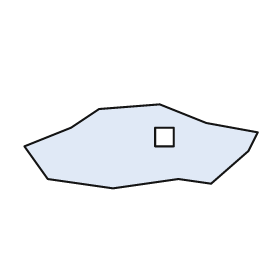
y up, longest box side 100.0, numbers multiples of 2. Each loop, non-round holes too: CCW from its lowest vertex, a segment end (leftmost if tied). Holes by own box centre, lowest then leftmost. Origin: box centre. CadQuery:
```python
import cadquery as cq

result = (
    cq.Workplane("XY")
    .moveTo(-12.0, -18.0)
    .lineTo(16.0, -14.0)
    .lineTo(30.0, -16.0)
    .lineTo(46.0, -2.0)
    .lineTo(50.0, 6.0)
    .lineTo(28.0, 10.0)
    .lineTo(8.0, 18.0)
    .lineTo(-18.0, 16.0)
    .lineTo(-30.0, 8.0)
    .lineTo(-50.0, 0.0)
    .lineTo(-40.0, -14.0)
    .close()
    .moveTo(6.0, 0.0)
    .lineTo(14.0, 0.0)
    .lineTo(14.0, 8.0)
    .lineTo(6.0, 8.0)
    .close()
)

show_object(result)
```